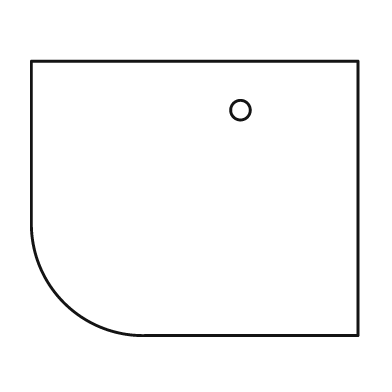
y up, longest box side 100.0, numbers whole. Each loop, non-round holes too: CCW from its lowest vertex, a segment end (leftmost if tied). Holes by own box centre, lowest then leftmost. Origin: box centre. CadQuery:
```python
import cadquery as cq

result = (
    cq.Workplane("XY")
    .moveTo(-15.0, -42.0)
    .lineTo(50.0, -42.0)
    .lineTo(50.0, 42.0)
    .lineTo(-50.0, 42.0)
    .lineTo(-50.0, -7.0)
    .threePointArc((-40.0, -32.0), (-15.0, -42.0))
    .close()
    .moveTo(14.0, 27.0)
    .circle(3.0)
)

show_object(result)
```